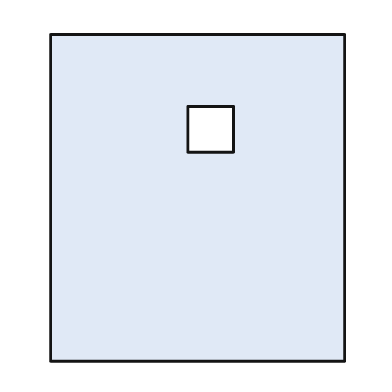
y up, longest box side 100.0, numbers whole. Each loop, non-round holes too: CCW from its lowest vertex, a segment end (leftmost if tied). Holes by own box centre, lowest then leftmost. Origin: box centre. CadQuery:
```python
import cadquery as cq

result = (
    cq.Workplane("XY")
    .moveTo(-45.0, -50.0)
    .lineTo(45.0, -50.0)
    .lineTo(45.0, 50.0)
    .lineTo(-45.0, 50.0)
    .close()
    .moveTo(-3.0, 14.0)
    .lineTo(11.0, 14.0)
    .lineTo(11.0, 28.0)
    .lineTo(-3.0, 28.0)
    .close()
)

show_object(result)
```